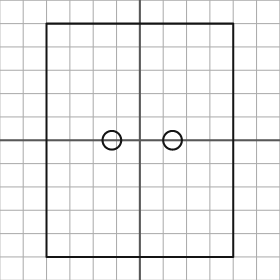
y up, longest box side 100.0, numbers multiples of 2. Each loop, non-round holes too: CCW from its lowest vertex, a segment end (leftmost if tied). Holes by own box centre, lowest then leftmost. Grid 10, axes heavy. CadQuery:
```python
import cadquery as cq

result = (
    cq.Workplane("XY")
    .moveTo(-40.0, -50.0)
    .lineTo(40.0, -50.0)
    .lineTo(40.0, 50.0)
    .lineTo(-40.0, 50.0)
    .close()
    .moveTo(-12.0, 0.0)
    .circle(4.0)
    .moveTo(14.0, 0.0)
    .circle(4.0)
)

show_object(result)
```